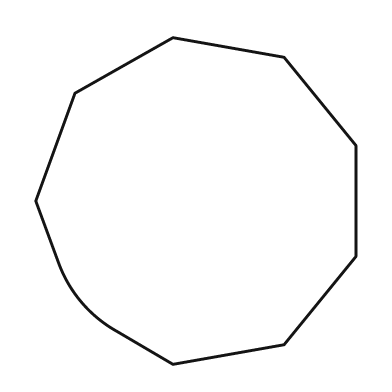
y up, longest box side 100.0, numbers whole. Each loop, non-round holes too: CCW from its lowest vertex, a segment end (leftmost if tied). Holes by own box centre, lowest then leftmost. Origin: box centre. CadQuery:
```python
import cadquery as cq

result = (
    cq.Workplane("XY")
    .moveTo(-7.0, -50.0)
    .lineTo(27.0, -44.0)
    .lineTo(49.0, -17.0)
    .lineTo(49.0, 17.0)
    .lineTo(27.0, 44.0)
    .lineTo(-7.0, 50.0)
    .lineTo(-37.0, 33.0)
    .lineTo(-49.0, 0.0)
    .lineTo(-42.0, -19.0)
    .threePointArc((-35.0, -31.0), (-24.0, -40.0))
    .close()
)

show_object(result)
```